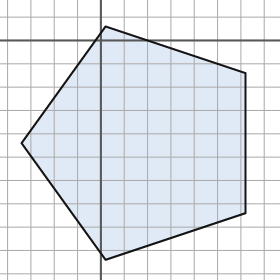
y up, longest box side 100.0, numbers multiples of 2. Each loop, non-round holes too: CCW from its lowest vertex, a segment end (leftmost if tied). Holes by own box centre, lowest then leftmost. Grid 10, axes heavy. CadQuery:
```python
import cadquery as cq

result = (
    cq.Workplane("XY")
    .moveTo(2.0, -94.0)
    .lineTo(62.0, -74.0)
    .lineTo(62.0, -14.0)
    .lineTo(2.0, 6.0)
    .lineTo(-34.0, -44.0)
    .close()
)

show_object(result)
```